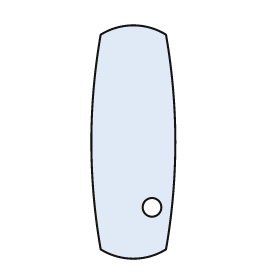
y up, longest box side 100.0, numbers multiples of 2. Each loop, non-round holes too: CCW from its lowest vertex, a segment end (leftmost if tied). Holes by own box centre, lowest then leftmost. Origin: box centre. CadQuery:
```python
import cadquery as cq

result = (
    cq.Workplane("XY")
    .moveTo(-14.0, -46.0)
    .threePointArc((0.0, -50.0), (14.0, -46.0))
    .threePointArc((18.0, 0.0), (14.0, 46.0))
    .threePointArc((0.0, 50.0), (-14.0, 46.0))
    .threePointArc((-18.0, 0.0), (-14.0, -46.0))
    .close()
    .moveTo(8.0, -28.0)
    .circle(4.0)
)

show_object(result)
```